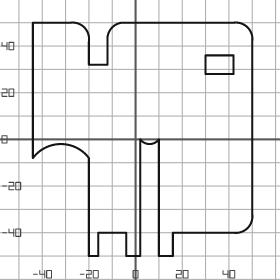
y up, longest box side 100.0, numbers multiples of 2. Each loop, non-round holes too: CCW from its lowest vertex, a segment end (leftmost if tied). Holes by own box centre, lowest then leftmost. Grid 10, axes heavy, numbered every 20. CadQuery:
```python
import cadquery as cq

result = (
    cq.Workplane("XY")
    .moveTo(-20.0, -50.0)
    .lineTo(-16.0, -50.0)
    .lineTo(-16.0, -40.0)
    .lineTo(-4.0, -40.0)
    .lineTo(-4.0, -50.0)
    .lineTo(2.0, -50.0)
    .lineTo(2.0, 0.0)
    .threePointArc((6.0, -2.0), (10.0, 0.0))
    .lineTo(10.0, -50.0)
    .lineTo(16.0, -50.0)
    .lineTo(16.0, -40.0)
    .lineTo(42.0, -40.0)
    .threePointArc((48.0, -38.0), (50.0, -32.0))
    .lineTo(50.0, 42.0)
    .threePointArc((48.0, 48.0), (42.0, 50.0))
    .lineTo(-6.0, 50.0)
    .threePointArc((-10.0, 48.0), (-12.0, 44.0))
    .lineTo(-12.0, 32.0)
    .lineTo(-20.0, 32.0)
    .lineTo(-20.0, 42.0)
    .threePointArc((-22.0, 48.0), (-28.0, 50.0))
    .lineTo(-44.0, 50.0)
    .lineTo(-44.0, -8.0)
    .threePointArc((-32.0, -2.0), (-20.0, -8.0))
    .close()
    .moveTo(30.0, 28.0)
    .lineTo(42.0, 28.0)
    .lineTo(42.0, 36.0)
    .lineTo(30.0, 36.0)
    .close()
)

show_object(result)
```